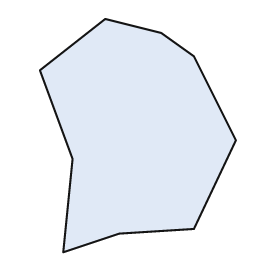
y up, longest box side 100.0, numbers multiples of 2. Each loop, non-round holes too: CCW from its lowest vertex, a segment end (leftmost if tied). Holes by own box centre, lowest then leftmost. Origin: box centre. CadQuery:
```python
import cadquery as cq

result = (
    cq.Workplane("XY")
    .moveTo(-32.0, -50.0)
    .lineTo(-8.0, -42.0)
    .lineTo(24.0, -40.0)
    .lineTo(42.0, -2.0)
    .lineTo(24.0, 34.0)
    .lineTo(10.0, 44.0)
    .lineTo(-14.0, 50.0)
    .lineTo(-42.0, 28.0)
    .lineTo(-28.0, -10.0)
    .close()
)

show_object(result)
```